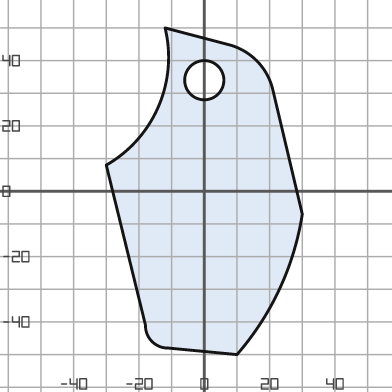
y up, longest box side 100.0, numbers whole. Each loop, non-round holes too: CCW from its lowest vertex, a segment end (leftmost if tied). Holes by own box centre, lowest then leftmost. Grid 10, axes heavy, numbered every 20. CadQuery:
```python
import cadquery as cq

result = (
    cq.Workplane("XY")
    .moveTo(10.0, -50.0)
    .threePointArc((23.0, -30.0), (30.0, -7.0))
    .lineTo(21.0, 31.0)
    .threePointArc((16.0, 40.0), (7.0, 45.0))
    .lineTo(-12.0, 50.0)
    .threePointArc((-14.0, 26.0), (-30.0, 8.0))
    .lineTo(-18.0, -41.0)
    .threePointArc((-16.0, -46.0), (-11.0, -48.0))
    .close()
    .moveTo(0.0, 34.0)
    .circle(6.0)
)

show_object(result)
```